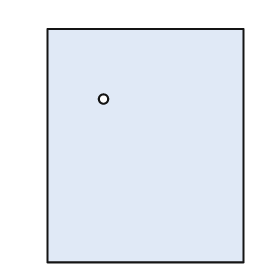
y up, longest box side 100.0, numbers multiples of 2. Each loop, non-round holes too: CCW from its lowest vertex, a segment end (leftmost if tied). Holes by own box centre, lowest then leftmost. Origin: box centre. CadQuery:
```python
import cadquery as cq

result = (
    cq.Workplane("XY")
    .moveTo(-42.0, -50.0)
    .lineTo(42.0, -50.0)
    .lineTo(42.0, 50.0)
    .lineTo(-42.0, 50.0)
    .close()
    .moveTo(-18.0, 20.0)
    .circle(2.0)
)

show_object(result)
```